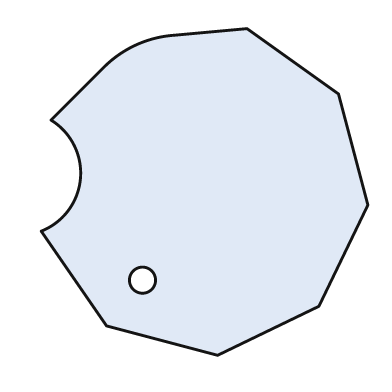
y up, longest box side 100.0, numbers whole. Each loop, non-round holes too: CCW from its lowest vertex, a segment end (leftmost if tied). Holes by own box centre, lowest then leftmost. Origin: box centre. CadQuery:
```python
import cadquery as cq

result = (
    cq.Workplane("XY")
    .moveTo(4.0, -50.0)
    .lineTo(35.0, -35.0)
    .lineTo(50.0, -4.0)
    .lineTo(41.0, 30.0)
    .lineTo(13.0, 50.0)
    .lineTo(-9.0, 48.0)
    .threePointArc((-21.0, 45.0), (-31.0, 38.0))
    .lineTo(-47.0, 22.0)
    .threePointArc((-38.0, 4.0), (-50.0, -12.0))
    .lineTo(-30.0, -41.0)
    .close()
    .moveTo(-19.0, -27.0)
    .circle(4.0)
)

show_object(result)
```